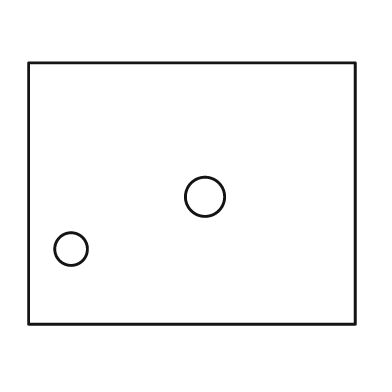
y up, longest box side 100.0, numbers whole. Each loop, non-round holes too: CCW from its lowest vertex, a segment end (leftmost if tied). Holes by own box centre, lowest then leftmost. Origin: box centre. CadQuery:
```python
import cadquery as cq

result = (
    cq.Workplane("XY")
    .moveTo(-50.0, -40.0)
    .lineTo(50.0, -40.0)
    .lineTo(50.0, 40.0)
    .lineTo(-50.0, 40.0)
    .close()
    .moveTo(-37.0, -17.0)
    .circle(5.0)
    .moveTo(4.0, -1.0)
    .circle(6.0)
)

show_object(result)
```